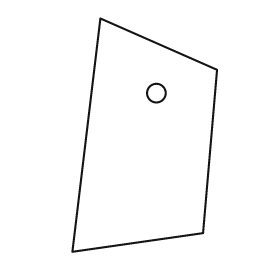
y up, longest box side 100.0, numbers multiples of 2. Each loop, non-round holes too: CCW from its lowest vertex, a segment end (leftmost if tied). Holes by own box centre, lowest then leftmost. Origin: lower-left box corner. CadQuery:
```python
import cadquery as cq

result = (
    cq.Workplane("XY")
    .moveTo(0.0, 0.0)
    .lineTo(56.0, 8.0)
    .lineTo(62.0, 78.0)
    .lineTo(12.0, 100.0)
    .close()
    .moveTo(36.0, 68.0)
    .circle(4.0)
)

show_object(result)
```